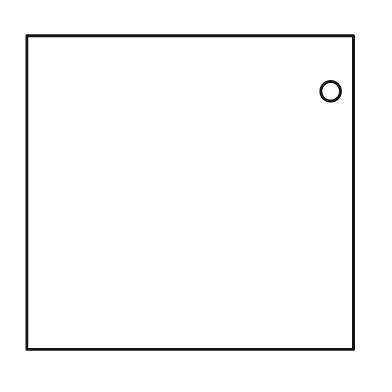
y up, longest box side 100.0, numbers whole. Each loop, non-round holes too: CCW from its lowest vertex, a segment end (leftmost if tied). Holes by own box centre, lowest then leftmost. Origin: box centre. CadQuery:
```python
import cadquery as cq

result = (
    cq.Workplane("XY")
    .moveTo(-50.0, -48.0)
    .lineTo(50.0, -48.0)
    .lineTo(50.0, 48.0)
    .lineTo(-50.0, 48.0)
    .close()
    .moveTo(43.0, 31.0)
    .circle(3.0)
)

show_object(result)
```